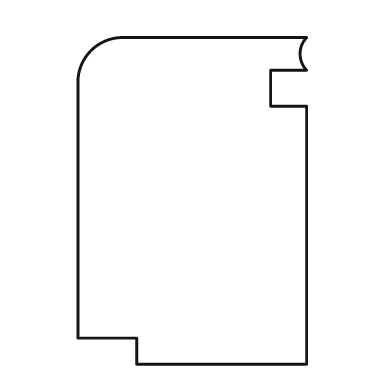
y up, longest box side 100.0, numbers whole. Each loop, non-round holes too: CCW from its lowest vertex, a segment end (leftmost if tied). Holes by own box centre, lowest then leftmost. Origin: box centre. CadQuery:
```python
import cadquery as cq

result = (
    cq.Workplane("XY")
    .moveTo(-17.0, -50.0)
    .lineTo(35.0, -50.0)
    .lineTo(35.0, 29.0)
    .lineTo(24.0, 29.0)
    .lineTo(24.0, 40.0)
    .lineTo(35.0, 40.0)
    .threePointArc((33.0, 45.0), (35.0, 50.0))
    .lineTo(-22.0, 50.0)
    .threePointArc((-31.0, 46.0), (-35.0, 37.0))
    .lineTo(-35.0, -42.0)
    .lineTo(-17.0, -42.0)
    .close()
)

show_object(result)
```